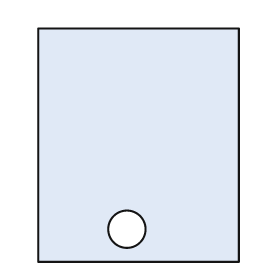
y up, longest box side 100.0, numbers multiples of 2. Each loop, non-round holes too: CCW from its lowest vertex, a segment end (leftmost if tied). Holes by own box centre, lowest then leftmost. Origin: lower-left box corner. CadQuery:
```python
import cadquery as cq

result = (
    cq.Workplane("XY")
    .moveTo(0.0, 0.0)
    .lineTo(86.0, 0.0)
    .lineTo(86.0, 100.0)
    .lineTo(0.0, 100.0)
    .close()
    .moveTo(38.0, 14.0)
    .circle(8.0)
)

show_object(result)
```